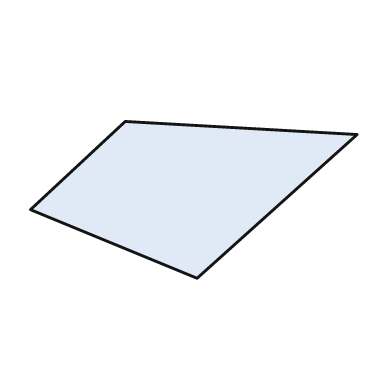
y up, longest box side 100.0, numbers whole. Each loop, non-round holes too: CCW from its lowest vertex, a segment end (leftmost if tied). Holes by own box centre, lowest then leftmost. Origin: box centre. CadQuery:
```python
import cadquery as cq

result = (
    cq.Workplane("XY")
    .moveTo(1.0, -24.0)
    .lineTo(50.0, 20.0)
    .lineTo(-21.0, 24.0)
    .lineTo(-50.0, -3.0)
    .close()
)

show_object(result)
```